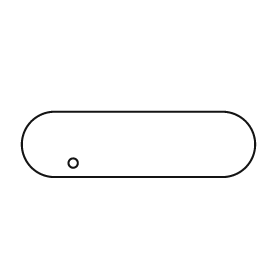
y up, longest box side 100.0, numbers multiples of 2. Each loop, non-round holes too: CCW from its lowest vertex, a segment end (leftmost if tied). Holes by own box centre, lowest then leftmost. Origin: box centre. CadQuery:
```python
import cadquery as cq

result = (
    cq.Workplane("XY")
    .moveTo(-36.0, -14.0)
    .lineTo(36.0, -14.0)
    .threePointArc((50.0, 0.0), (36.0, 14.0))
    .lineTo(-36.0, 14.0)
    .threePointArc((-50.0, 0.0), (-36.0, -14.0))
    .close()
    .moveTo(-28.0, -8.0)
    .circle(2.0)
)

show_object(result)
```